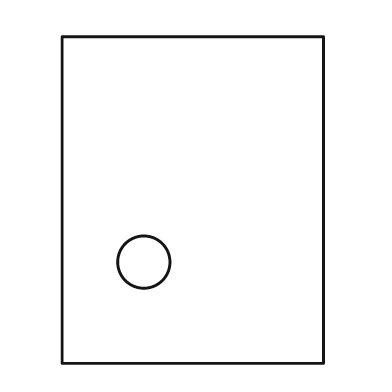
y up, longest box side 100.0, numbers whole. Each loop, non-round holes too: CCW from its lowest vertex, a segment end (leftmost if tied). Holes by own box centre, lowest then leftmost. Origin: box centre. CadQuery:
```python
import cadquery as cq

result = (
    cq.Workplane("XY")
    .moveTo(-40.0, -50.0)
    .lineTo(40.0, -50.0)
    .lineTo(40.0, 50.0)
    .lineTo(-40.0, 50.0)
    .close()
    .moveTo(-15.0, -19.0)
    .circle(8.0)
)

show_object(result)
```